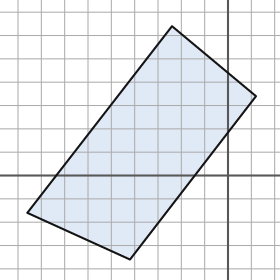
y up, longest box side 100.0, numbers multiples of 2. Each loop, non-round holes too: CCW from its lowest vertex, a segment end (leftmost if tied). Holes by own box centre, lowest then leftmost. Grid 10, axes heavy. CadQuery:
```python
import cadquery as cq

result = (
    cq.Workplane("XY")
    .moveTo(-42.0, -36.0)
    .lineTo(12.0, 34.0)
    .lineTo(-24.0, 64.0)
    .lineTo(-86.0, -16.0)
    .close()
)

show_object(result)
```